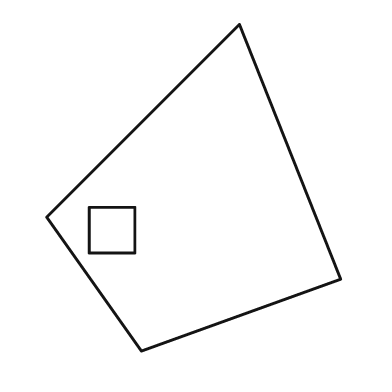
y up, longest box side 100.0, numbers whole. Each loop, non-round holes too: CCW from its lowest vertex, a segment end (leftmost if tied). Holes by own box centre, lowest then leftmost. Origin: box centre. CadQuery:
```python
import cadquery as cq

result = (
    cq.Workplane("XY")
    .moveTo(-16.0, -50.0)
    .lineTo(45.0, -28.0)
    .lineTo(14.0, 50.0)
    .lineTo(-45.0, -9.0)
    .close()
    .moveTo(-32.0, -20.0)
    .lineTo(-18.0, -20.0)
    .lineTo(-18.0, -6.0)
    .lineTo(-32.0, -6.0)
    .close()
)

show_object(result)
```